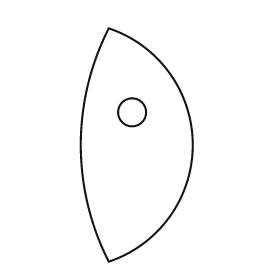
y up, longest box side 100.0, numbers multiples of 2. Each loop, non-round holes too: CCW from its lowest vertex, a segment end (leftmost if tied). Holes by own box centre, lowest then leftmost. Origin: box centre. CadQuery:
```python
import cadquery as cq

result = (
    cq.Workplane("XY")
    .moveTo(-12.0, -50.0)
    .threePointArc((24.0, 0.0), (-12.0, 50.0))
    .threePointArc((-24.0, 0.0), (-12.0, -50.0))
    .close()
    .moveTo(-2.0, 14.0)
    .circle(6.0)
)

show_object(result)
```